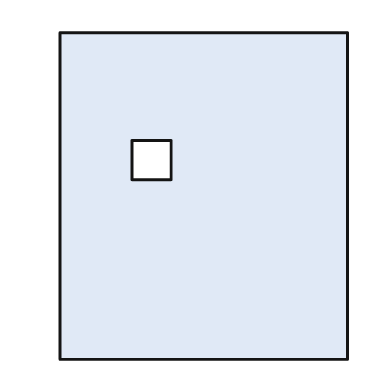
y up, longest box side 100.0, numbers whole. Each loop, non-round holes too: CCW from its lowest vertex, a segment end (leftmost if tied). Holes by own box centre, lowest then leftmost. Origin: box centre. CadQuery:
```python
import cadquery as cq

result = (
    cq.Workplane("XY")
    .moveTo(-44.0, -50.0)
    .lineTo(44.0, -50.0)
    .lineTo(44.0, 50.0)
    .lineTo(-44.0, 50.0)
    .close()
    .moveTo(-22.0, 5.0)
    .lineTo(-10.0, 5.0)
    .lineTo(-10.0, 17.0)
    .lineTo(-22.0, 17.0)
    .close()
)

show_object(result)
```